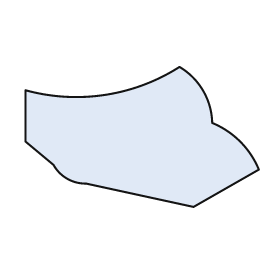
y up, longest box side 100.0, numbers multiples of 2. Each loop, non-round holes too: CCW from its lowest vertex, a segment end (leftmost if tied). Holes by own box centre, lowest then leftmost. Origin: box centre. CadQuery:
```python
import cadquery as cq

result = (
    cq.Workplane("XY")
    .moveTo(22.0, -30.0)
    .lineTo(50.0, -14.0)
    .threePointArc((42.0, -2.0), (30.0, 6.0))
    .threePointArc((26.0, 20.0), (16.0, 30.0))
    .threePointArc((-16.0, 18.0), (-50.0, 20.0))
    .lineTo(-50.0, -2.0)
    .lineTo(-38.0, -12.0)
    .threePointArc((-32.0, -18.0), (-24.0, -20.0))
    .close()
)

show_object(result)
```